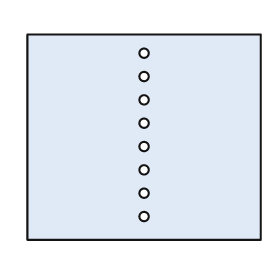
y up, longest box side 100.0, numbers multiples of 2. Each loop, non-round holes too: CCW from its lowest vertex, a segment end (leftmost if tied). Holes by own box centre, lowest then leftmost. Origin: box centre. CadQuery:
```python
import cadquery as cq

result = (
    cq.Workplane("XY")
    .moveTo(-50.0, -44.0)
    .lineTo(50.0, -44.0)
    .lineTo(50.0, 44.0)
    .lineTo(-50.0, 44.0)
    .close()
    .moveTo(0.0, -34.0)
    .circle(2.0)
    .moveTo(0.0, -24.0)
    .circle(2.0)
    .moveTo(0.0, -14.0)
    .circle(2.0)
    .moveTo(0.0, -4.0)
    .circle(2.0)
    .moveTo(0.0, 6.0)
    .circle(2.0)
    .moveTo(0.0, 16.0)
    .circle(2.0)
    .moveTo(0.0, 26.0)
    .circle(2.0)
    .moveTo(0.0, 36.0)
    .circle(2.0)
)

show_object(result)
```